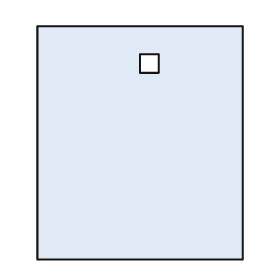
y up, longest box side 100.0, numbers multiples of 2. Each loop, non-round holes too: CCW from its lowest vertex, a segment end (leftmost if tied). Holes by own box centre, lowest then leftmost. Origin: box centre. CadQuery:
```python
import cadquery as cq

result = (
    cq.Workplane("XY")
    .moveTo(-44.0, -50.0)
    .lineTo(44.0, -50.0)
    .lineTo(44.0, 50.0)
    .lineTo(-44.0, 50.0)
    .close()
    .moveTo(0.0, 30.0)
    .lineTo(8.0, 30.0)
    .lineTo(8.0, 38.0)
    .lineTo(0.0, 38.0)
    .close()
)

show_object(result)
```